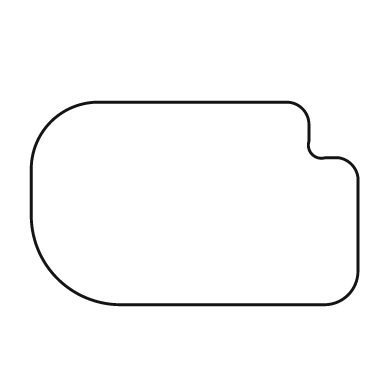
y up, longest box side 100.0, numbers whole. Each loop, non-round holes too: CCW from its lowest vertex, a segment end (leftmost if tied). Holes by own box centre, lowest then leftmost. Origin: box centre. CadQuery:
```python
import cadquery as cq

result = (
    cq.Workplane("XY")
    .moveTo(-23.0, -31.0)
    .lineTo(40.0, -31.0)
    .threePointArc((47.0, -28.0), (50.0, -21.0))
    .lineTo(50.0, 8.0)
    .threePointArc((48.0, 12.0), (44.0, 14.0))
    .lineTo(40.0, 14.0)
    .threePointArc((36.0, 15.0), (35.0, 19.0))
    .lineTo(35.0, 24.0)
    .threePointArc((33.0, 29.0), (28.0, 31.0))
    .lineTo(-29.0, 31.0)
    .threePointArc((-44.0, 25.0), (-50.0, 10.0))
    .lineTo(-50.0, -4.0)
    .threePointArc((-42.0, -23.0), (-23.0, -31.0))
    .close()
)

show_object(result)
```